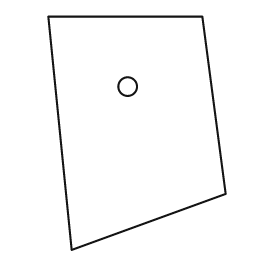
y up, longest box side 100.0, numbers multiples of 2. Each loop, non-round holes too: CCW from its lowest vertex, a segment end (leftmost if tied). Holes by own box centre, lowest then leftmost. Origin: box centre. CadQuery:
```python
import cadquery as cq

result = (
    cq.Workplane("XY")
    .moveTo(-28.0, -50.0)
    .lineTo(38.0, -26.0)
    .lineTo(28.0, 50.0)
    .lineTo(-38.0, 50.0)
    .close()
    .moveTo(-4.0, 20.0)
    .circle(4.0)
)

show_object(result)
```